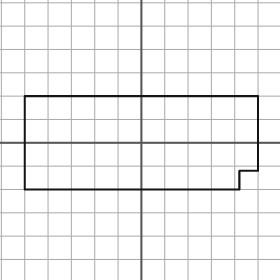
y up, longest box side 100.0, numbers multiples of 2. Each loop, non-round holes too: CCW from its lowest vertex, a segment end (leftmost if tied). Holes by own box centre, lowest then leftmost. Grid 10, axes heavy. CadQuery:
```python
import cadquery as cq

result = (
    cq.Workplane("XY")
    .moveTo(-50.0, -20.0)
    .lineTo(42.0, -20.0)
    .lineTo(42.0, -12.0)
    .lineTo(50.0, -12.0)
    .lineTo(50.0, 20.0)
    .lineTo(-50.0, 20.0)
    .close()
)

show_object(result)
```